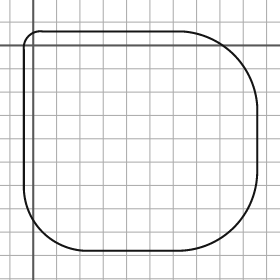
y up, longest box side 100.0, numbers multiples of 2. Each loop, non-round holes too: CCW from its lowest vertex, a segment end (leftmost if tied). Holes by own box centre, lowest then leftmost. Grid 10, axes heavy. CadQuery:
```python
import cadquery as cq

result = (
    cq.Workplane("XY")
    .moveTo(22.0, -88.0)
    .lineTo(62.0, -88.0)
    .threePointArc((86.0, -78.0), (96.0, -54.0))
    .lineTo(96.0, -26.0)
    .threePointArc((86.0, -4.0), (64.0, 6.0))
    .lineTo(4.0, 6.0)
    .threePointArc((-2.0, 4.0), (-4.0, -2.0))
    .lineTo(-4.0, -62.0)
    .threePointArc((4.0, -80.0), (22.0, -88.0))
    .close()
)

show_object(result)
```